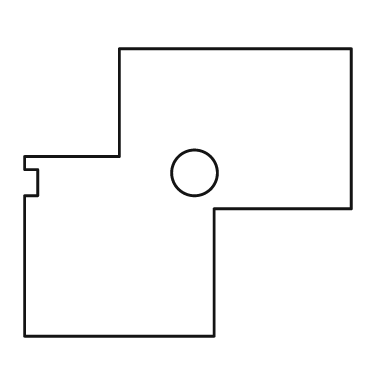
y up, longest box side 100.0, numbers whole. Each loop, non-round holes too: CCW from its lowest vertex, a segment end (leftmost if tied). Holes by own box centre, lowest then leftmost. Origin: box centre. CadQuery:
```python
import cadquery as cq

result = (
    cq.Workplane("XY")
    .moveTo(-50.0, -44.0)
    .lineTo(8.0, -44.0)
    .lineTo(8.0, -5.0)
    .lineTo(50.0, -5.0)
    .lineTo(50.0, 44.0)
    .lineTo(-21.0, 44.0)
    .lineTo(-21.0, 11.0)
    .lineTo(-50.0, 11.0)
    .lineTo(-50.0, 7.0)
    .lineTo(-46.0, 7.0)
    .lineTo(-46.0, -1.0)
    .lineTo(-50.0, -1.0)
    .close()
    .moveTo(2.0, 6.0)
    .circle(7.0)
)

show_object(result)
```